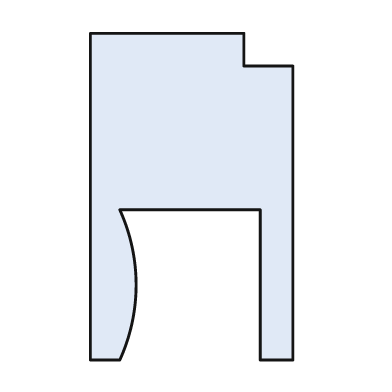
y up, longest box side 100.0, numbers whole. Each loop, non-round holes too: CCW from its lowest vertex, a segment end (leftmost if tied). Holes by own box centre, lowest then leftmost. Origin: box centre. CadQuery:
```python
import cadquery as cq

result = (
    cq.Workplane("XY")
    .moveTo(-31.0, -50.0)
    .lineTo(-22.0, -50.0)
    .threePointArc((-17.0, -27.0), (-22.0, -4.0))
    .lineTo(21.0, -4.0)
    .lineTo(21.0, -50.0)
    .lineTo(31.0, -50.0)
    .lineTo(31.0, 40.0)
    .lineTo(16.0, 40.0)
    .lineTo(16.0, 50.0)
    .lineTo(-31.0, 50.0)
    .close()
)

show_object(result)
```